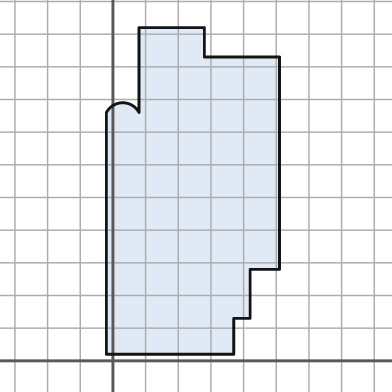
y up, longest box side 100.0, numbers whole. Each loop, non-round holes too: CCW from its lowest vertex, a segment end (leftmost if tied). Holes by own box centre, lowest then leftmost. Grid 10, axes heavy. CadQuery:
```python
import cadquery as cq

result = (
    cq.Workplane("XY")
    .moveTo(-2.0, 2.0)
    .lineTo(37.0, 2.0)
    .lineTo(37.0, 13.0)
    .lineTo(42.0, 13.0)
    .lineTo(42.0, 28.0)
    .lineTo(51.0, 28.0)
    .lineTo(51.0, 93.0)
    .lineTo(28.0, 93.0)
    .lineTo(28.0, 102.0)
    .lineTo(8.0, 102.0)
    .lineTo(8.0, 76.0)
    .threePointArc((3.0, 79.0), (-2.0, 76.0))
    .close()
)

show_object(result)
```